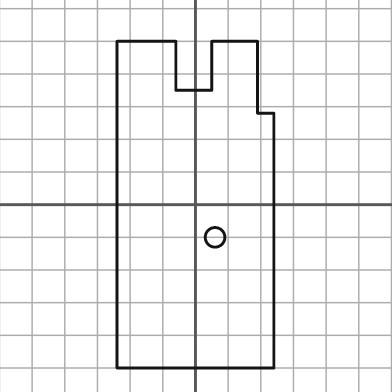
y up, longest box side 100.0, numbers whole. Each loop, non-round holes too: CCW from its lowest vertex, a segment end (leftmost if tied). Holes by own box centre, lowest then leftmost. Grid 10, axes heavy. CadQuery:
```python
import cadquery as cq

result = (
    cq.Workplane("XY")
    .moveTo(-24.0, -50.0)
    .lineTo(24.0, -50.0)
    .lineTo(24.0, 28.0)
    .lineTo(19.0, 28.0)
    .lineTo(19.0, 50.0)
    .lineTo(5.0, 50.0)
    .lineTo(5.0, 35.0)
    .lineTo(-6.0, 35.0)
    .lineTo(-6.0, 50.0)
    .lineTo(-24.0, 50.0)
    .close()
    .moveTo(6.0, -10.0)
    .circle(3.0)
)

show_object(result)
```